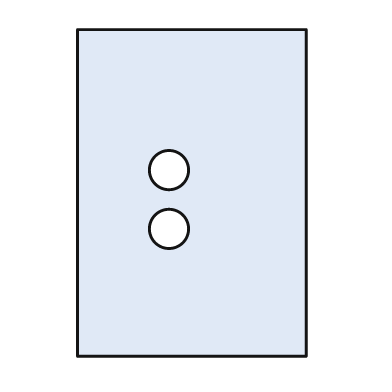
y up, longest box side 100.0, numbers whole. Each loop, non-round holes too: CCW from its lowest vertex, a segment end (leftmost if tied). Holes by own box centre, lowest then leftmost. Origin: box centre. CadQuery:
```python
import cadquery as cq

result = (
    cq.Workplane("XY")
    .moveTo(-35.0, -50.0)
    .lineTo(35.0, -50.0)
    .lineTo(35.0, 50.0)
    .lineTo(-35.0, 50.0)
    .close()
    .moveTo(-7.0, -11.0)
    .circle(6.0)
    .moveTo(-7.0, 7.0)
    .circle(6.0)
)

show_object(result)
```